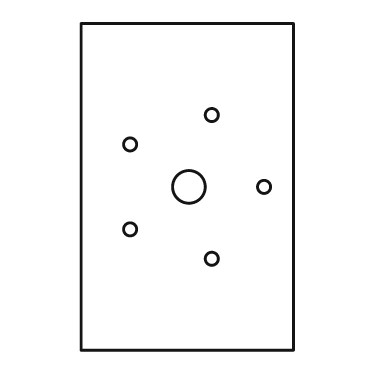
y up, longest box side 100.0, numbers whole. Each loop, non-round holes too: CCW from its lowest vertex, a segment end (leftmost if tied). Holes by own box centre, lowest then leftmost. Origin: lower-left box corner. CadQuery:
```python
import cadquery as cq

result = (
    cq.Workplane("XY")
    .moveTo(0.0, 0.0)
    .lineTo(65.0, 0.0)
    .lineTo(65.0, 100.0)
    .lineTo(0.0, 100.0)
    .close()
    .moveTo(40.0, 28.0)
    .circle(2.0)
    .moveTo(15.0, 37.0)
    .circle(2.0)
    .moveTo(33.0, 50.0)
    .circle(5.0)
    .moveTo(56.0, 50.0)
    .circle(2.0)
    .moveTo(15.0, 63.0)
    .circle(2.0)
    .moveTo(40.0, 72.0)
    .circle(2.0)
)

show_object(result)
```